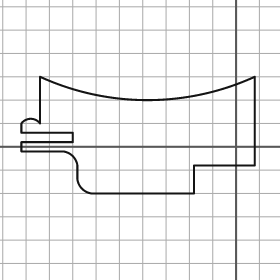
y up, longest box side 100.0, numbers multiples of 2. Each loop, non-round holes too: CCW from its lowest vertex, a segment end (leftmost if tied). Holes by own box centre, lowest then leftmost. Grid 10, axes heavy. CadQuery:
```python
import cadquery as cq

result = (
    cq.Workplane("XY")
    .moveTo(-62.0, -20.0)
    .lineTo(-18.0, -20.0)
    .lineTo(-18.0, -8.0)
    .lineTo(8.0, -8.0)
    .lineTo(8.0, 30.0)
    .threePointArc((-38.0, 20.0), (-84.0, 30.0))
    .lineTo(-84.0, 10.0)
    .threePointArc((-88.0, 12.0), (-92.0, 10.0))
    .lineTo(-92.0, 6.0)
    .lineTo(-70.0, 6.0)
    .lineTo(-70.0, 2.0)
    .lineTo(-92.0, 2.0)
    .lineTo(-92.0, -2.0)
    .lineTo(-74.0, -2.0)
    .threePointArc((-70.0, -4.0), (-68.0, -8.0))
    .lineTo(-68.0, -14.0)
    .threePointArc((-66.0, -18.0), (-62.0, -20.0))
    .close()
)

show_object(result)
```